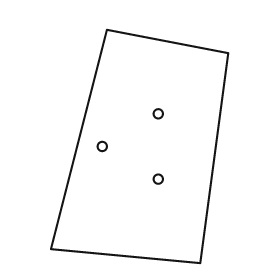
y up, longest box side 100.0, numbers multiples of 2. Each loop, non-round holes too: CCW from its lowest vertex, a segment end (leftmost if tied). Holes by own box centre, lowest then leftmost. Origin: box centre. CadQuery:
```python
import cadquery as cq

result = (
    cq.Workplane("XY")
    .moveTo(26.0, -50.0)
    .lineTo(38.0, 40.0)
    .lineTo(-14.0, 50.0)
    .lineTo(-38.0, -44.0)
    .close()
    .moveTo(8.0, -14.0)
    .circle(2.0)
    .moveTo(-16.0, 0.0)
    .circle(2.0)
    .moveTo(8.0, 14.0)
    .circle(2.0)
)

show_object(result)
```